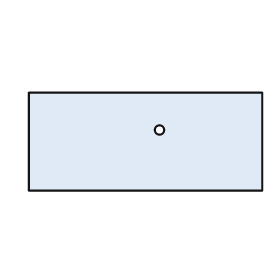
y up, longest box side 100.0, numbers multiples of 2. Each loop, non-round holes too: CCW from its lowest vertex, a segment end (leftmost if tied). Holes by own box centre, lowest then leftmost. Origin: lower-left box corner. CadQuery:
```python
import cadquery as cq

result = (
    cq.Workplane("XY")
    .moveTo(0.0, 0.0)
    .lineTo(100.0, 0.0)
    .lineTo(100.0, 42.0)
    .lineTo(0.0, 42.0)
    .close()
    .moveTo(56.0, 26.0)
    .circle(2.0)
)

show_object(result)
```